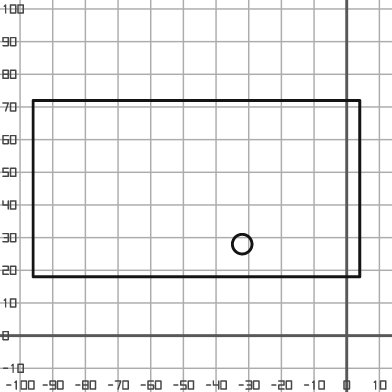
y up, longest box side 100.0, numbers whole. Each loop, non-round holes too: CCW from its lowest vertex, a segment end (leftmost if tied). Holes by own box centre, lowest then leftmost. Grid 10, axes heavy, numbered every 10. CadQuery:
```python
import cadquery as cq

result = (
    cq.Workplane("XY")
    .moveTo(-96.0, 18.0)
    .lineTo(4.0, 18.0)
    .lineTo(4.0, 72.0)
    .lineTo(-96.0, 72.0)
    .close()
    .moveTo(-32.0, 28.0)
    .circle(3.0)
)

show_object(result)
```